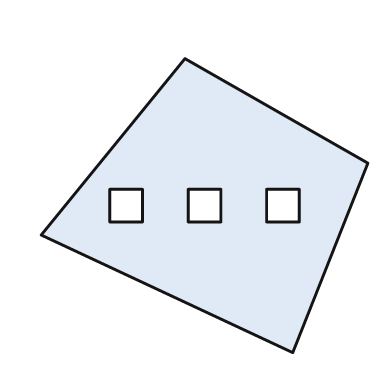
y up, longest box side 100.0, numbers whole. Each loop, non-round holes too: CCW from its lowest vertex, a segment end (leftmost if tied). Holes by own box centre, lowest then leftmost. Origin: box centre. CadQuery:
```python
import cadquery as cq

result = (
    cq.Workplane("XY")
    .moveTo(27.0, -45.0)
    .lineTo(50.0, 13.0)
    .lineTo(-6.0, 45.0)
    .lineTo(-50.0, -9.0)
    .close()
    .moveTo(-29.0, -5.0)
    .lineTo(-19.0, -5.0)
    .lineTo(-19.0, 5.0)
    .lineTo(-29.0, 5.0)
    .close()
    .moveTo(-5.0, -5.0)
    .lineTo(5.0, -5.0)
    .lineTo(5.0, 5.0)
    .lineTo(-5.0, 5.0)
    .close()
    .moveTo(19.0, -5.0)
    .lineTo(29.0, -5.0)
    .lineTo(29.0, 5.0)
    .lineTo(19.0, 5.0)
    .close()
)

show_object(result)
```